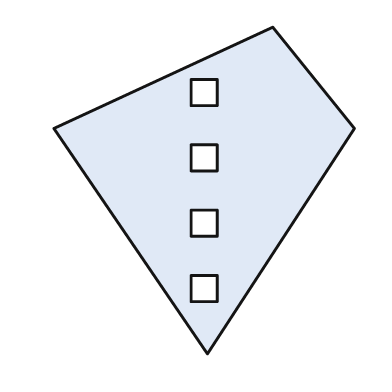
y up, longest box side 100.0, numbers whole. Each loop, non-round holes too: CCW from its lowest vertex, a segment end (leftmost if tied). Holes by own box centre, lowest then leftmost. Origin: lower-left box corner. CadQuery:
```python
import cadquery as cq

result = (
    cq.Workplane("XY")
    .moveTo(47.0, 0.0)
    .lineTo(92.0, 69.0)
    .lineTo(67.0, 100.0)
    .lineTo(0.0, 69.0)
    .close()
    .moveTo(42.0, 16.0)
    .lineTo(50.0, 16.0)
    .lineTo(50.0, 24.0)
    .lineTo(42.0, 24.0)
    .close()
    .moveTo(42.0, 36.0)
    .lineTo(50.0, 36.0)
    .lineTo(50.0, 44.0)
    .lineTo(42.0, 44.0)
    .close()
    .moveTo(42.0, 56.0)
    .lineTo(50.0, 56.0)
    .lineTo(50.0, 64.0)
    .lineTo(42.0, 64.0)
    .close()
    .moveTo(42.0, 76.0)
    .lineTo(50.0, 76.0)
    .lineTo(50.0, 84.0)
    .lineTo(42.0, 84.0)
    .close()
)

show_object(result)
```